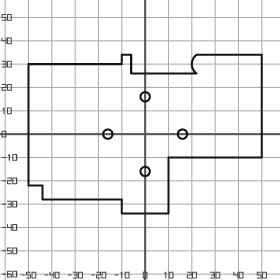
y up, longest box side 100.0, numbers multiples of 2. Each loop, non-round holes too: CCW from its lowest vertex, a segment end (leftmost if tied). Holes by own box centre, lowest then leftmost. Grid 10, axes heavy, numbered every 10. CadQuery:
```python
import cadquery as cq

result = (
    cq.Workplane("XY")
    .moveTo(-10.0, -34.0)
    .lineTo(10.0, -34.0)
    .lineTo(10.0, -10.0)
    .lineTo(50.0, -10.0)
    .lineTo(50.0, 34.0)
    .lineTo(22.0, 34.0)
    .threePointArc((20.0, 30.0), (22.0, 26.0))
    .lineTo(-6.0, 26.0)
    .lineTo(-6.0, 34.0)
    .lineTo(-10.0, 34.0)
    .lineTo(-10.0, 30.0)
    .lineTo(-50.0, 30.0)
    .lineTo(-50.0, -22.0)
    .lineTo(-44.0, -22.0)
    .lineTo(-44.0, -28.0)
    .lineTo(-10.0, -28.0)
    .close()
    .moveTo(0.0, -16.0)
    .circle(2.0)
    .moveTo(-16.0, 0.0)
    .circle(2.0)
    .moveTo(16.0, 0.0)
    .circle(2.0)
    .moveTo(0.0, 16.0)
    .circle(2.0)
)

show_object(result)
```